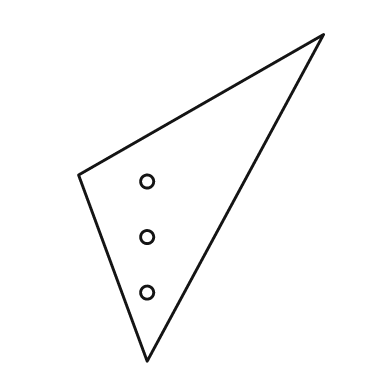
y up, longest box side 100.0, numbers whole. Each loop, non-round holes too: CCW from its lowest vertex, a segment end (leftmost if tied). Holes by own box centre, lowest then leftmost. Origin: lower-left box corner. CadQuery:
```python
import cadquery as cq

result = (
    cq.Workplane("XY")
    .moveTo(21.0, 0.0)
    .lineTo(75.0, 100.0)
    .lineTo(0.0, 57.0)
    .close()
    .moveTo(21.0, 21.0)
    .circle(2.0)
    .moveTo(21.0, 38.0)
    .circle(2.0)
    .moveTo(21.0, 55.0)
    .circle(2.0)
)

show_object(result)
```